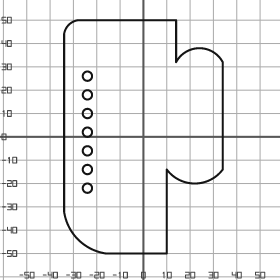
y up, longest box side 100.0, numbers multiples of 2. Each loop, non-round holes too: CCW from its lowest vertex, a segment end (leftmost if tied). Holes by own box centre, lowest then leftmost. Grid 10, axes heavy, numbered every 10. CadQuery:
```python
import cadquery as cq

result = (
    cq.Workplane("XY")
    .moveTo(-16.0, -50.0)
    .lineTo(10.0, -50.0)
    .lineTo(10.0, -14.0)
    .threePointArc((22.0, -20.0), (34.0, -14.0))
    .lineTo(34.0, 32.0)
    .threePointArc((24.0, 38.0), (14.0, 32.0))
    .lineTo(14.0, 50.0)
    .lineTo(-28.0, 50.0)
    .threePointArc((-32.0, 48.0), (-34.0, 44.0))
    .lineTo(-34.0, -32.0)
    .threePointArc((-28.0, -44.0), (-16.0, -50.0))
    .close()
    .moveTo(-24.0, -22.0)
    .circle(2.0)
    .moveTo(-24.0, -14.0)
    .circle(2.0)
    .moveTo(-24.0, -6.0)
    .circle(2.0)
    .moveTo(-24.0, 2.0)
    .circle(2.0)
    .moveTo(-24.0, 10.0)
    .circle(2.0)
    .moveTo(-24.0, 18.0)
    .circle(2.0)
    .moveTo(-24.0, 26.0)
    .circle(2.0)
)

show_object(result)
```